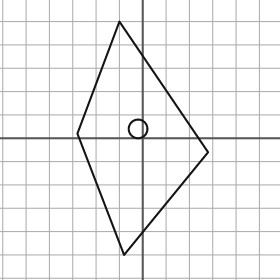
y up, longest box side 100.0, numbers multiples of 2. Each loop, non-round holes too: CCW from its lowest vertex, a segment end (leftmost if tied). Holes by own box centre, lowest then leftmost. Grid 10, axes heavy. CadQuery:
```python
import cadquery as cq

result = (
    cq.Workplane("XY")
    .moveTo(-8.0, -50.0)
    .lineTo(28.0, -6.0)
    .lineTo(-10.0, 50.0)
    .lineTo(-28.0, 2.0)
    .close()
    .moveTo(-2.0, 4.0)
    .circle(4.0)
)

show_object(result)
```